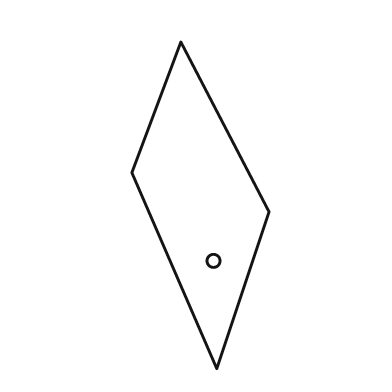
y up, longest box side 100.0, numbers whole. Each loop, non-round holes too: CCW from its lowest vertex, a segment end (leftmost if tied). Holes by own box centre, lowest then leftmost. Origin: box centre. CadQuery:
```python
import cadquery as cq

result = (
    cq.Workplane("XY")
    .moveTo(5.0, -50.0)
    .lineTo(21.0, -2.0)
    .lineTo(-6.0, 50.0)
    .lineTo(-21.0, 10.0)
    .close()
    .moveTo(4.0, -17.0)
    .circle(2.0)
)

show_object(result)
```